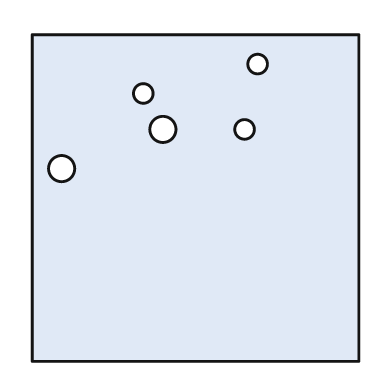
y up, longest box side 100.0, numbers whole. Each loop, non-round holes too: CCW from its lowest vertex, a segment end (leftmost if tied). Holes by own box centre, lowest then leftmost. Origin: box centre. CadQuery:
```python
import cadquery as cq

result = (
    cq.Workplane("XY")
    .moveTo(-50.0, -50.0)
    .lineTo(50.0, -50.0)
    .lineTo(50.0, 50.0)
    .lineTo(-50.0, 50.0)
    .close()
    .moveTo(-41.0, 9.0)
    .circle(4.0)
    .moveTo(-10.0, 21.0)
    .circle(4.0)
    .moveTo(15.0, 21.0)
    .circle(3.0)
    .moveTo(-16.0, 32.0)
    .circle(3.0)
    .moveTo(19.0, 41.0)
    .circle(3.0)
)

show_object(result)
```